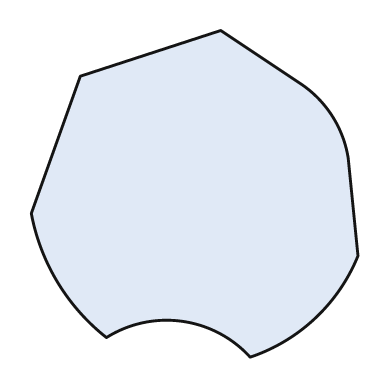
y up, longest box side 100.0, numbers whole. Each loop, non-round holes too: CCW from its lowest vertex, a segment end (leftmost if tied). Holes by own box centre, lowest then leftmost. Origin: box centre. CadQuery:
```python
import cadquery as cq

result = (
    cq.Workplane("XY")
    .moveTo(17.0, -50.0)
    .threePointArc((37.0, -38.0), (50.0, -19.0))
    .lineTo(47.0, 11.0)
    .threePointArc((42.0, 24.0), (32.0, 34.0))
    .lineTo(8.0, 50.0)
    .lineTo(-35.0, 36.0)
    .lineTo(-50.0, -6.0)
    .threePointArc((-42.0, -27.0), (-27.0, -44.0))
    .threePointArc((-4.0, -39.0), (17.0, -50.0))
    .close()
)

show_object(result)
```